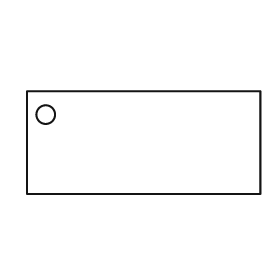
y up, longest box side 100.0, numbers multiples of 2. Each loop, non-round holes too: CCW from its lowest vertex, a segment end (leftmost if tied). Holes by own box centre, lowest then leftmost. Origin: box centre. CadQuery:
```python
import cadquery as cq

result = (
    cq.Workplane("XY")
    .moveTo(-50.0, -22.0)
    .lineTo(50.0, -22.0)
    .lineTo(50.0, 22.0)
    .lineTo(-50.0, 22.0)
    .close()
    .moveTo(-42.0, 12.0)
    .circle(4.0)
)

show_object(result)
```